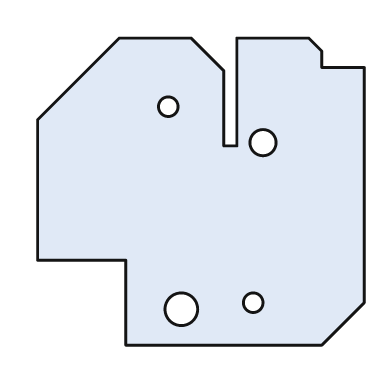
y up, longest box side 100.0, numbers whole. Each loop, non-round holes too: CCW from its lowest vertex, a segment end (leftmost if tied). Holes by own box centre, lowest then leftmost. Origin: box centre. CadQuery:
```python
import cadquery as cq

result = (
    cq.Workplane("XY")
    .moveTo(-23.0, -47.0)
    .lineTo(37.0, -47.0)
    .lineTo(50.0, -34.0)
    .lineTo(50.0, 38.0)
    .lineTo(37.0, 38.0)
    .lineTo(37.0, 43.0)
    .lineTo(33.0, 47.0)
    .lineTo(11.0, 47.0)
    .lineTo(11.0, 14.0)
    .lineTo(7.0, 14.0)
    .lineTo(7.0, 37.0)
    .lineTo(-3.0, 47.0)
    .lineTo(-25.0, 47.0)
    .lineTo(-50.0, 22.0)
    .lineTo(-50.0, -21.0)
    .lineTo(-23.0, -21.0)
    .close()
    .moveTo(-6.0, -36.0)
    .circle(5.0)
    .moveTo(16.0, -34.0)
    .circle(3.0)
    .moveTo(19.0, 15.0)
    .circle(4.0)
    .moveTo(-10.0, 26.0)
    .circle(3.0)
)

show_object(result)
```